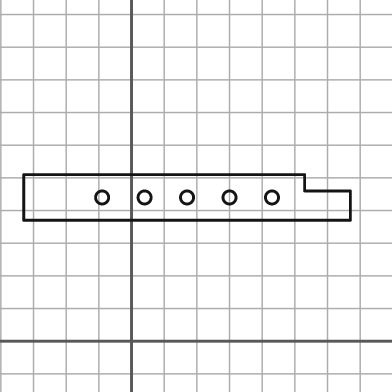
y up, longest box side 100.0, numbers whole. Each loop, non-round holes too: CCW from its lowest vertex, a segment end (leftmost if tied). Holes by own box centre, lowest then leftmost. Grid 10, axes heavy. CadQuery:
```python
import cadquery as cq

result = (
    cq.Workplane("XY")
    .moveTo(-33.0, 37.0)
    .lineTo(67.0, 37.0)
    .lineTo(67.0, 46.0)
    .lineTo(53.0, 46.0)
    .lineTo(53.0, 51.0)
    .lineTo(-33.0, 51.0)
    .close()
    .moveTo(-9.0, 44.0)
    .circle(2.0)
    .moveTo(4.0, 44.0)
    .circle(2.0)
    .moveTo(17.0, 44.0)
    .circle(2.0)
    .moveTo(30.0, 44.0)
    .circle(2.0)
    .moveTo(43.0, 44.0)
    .circle(2.0)
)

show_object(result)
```